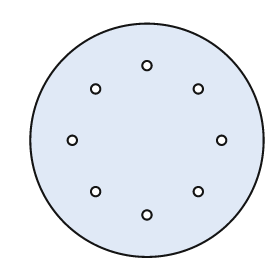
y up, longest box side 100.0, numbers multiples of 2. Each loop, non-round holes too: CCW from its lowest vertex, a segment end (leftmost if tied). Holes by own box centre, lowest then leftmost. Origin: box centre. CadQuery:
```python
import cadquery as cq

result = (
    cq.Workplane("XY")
    .moveTo(0.0, 0.0)
    .circle(50.0)
    .moveTo(0.0, -32.0)
    .circle(2.0)
    .moveTo(-22.0, -22.0)
    .circle(2.0)
    .moveTo(22.0, -22.0)
    .circle(2.0)
    .moveTo(-32.0, 0.0)
    .circle(2.0)
    .moveTo(32.0, 0.0)
    .circle(2.0)
    .moveTo(-22.0, 22.0)
    .circle(2.0)
    .moveTo(22.0, 22.0)
    .circle(2.0)
    .moveTo(0.0, 32.0)
    .circle(2.0)
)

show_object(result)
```